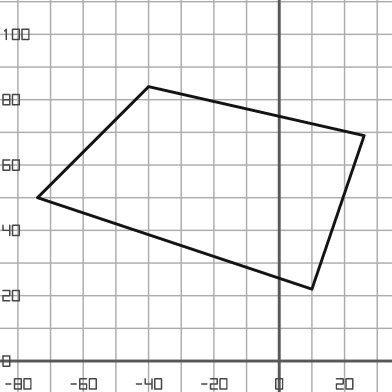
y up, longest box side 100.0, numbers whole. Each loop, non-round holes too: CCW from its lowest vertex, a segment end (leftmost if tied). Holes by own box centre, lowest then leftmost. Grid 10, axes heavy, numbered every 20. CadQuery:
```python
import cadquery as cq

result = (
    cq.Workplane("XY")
    .moveTo(10.0, 22.0)
    .lineTo(26.0, 69.0)
    .lineTo(-40.0, 84.0)
    .lineTo(-74.0, 50.0)
    .close()
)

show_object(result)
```